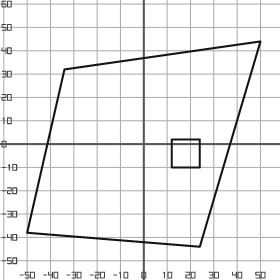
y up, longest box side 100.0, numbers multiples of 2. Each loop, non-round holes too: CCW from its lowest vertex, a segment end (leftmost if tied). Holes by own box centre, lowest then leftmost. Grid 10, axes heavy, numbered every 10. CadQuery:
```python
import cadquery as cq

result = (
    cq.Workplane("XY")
    .moveTo(24.0, -44.0)
    .lineTo(50.0, 44.0)
    .lineTo(-34.0, 32.0)
    .lineTo(-50.0, -38.0)
    .close()
    .moveTo(12.0, -10.0)
    .lineTo(24.0, -10.0)
    .lineTo(24.0, 2.0)
    .lineTo(12.0, 2.0)
    .close()
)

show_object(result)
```